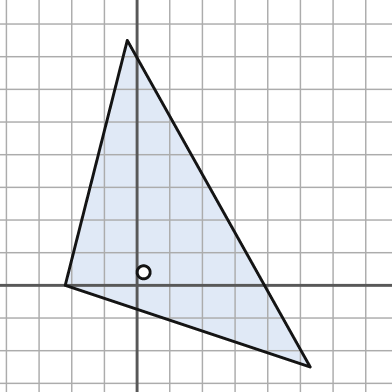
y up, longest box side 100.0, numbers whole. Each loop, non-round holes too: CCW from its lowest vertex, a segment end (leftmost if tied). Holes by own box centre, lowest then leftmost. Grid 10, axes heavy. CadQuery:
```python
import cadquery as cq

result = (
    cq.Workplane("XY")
    .moveTo(53.0, -25.0)
    .lineTo(-3.0, 75.0)
    .lineTo(-22.0, 0.0)
    .close()
    .moveTo(2.0, 4.0)
    .circle(2.0)
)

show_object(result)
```